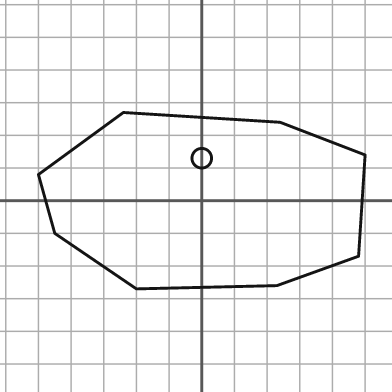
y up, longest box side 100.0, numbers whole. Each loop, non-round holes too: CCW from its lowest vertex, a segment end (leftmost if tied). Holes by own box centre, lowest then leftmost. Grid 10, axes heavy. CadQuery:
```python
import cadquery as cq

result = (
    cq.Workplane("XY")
    .moveTo(-20.0, -27.0)
    .lineTo(23.0, -26.0)
    .lineTo(48.0, -17.0)
    .lineTo(50.0, 14.0)
    .lineTo(24.0, 24.0)
    .lineTo(-24.0, 27.0)
    .lineTo(-50.0, 8.0)
    .lineTo(-45.0, -10.0)
    .close()
    .moveTo(0.0, 13.0)
    .circle(3.0)
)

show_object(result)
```